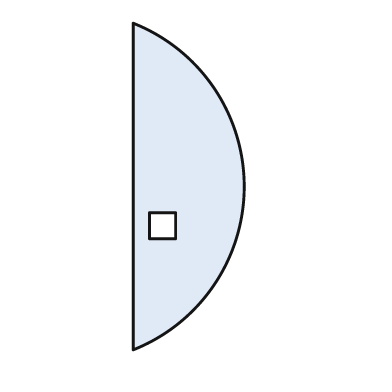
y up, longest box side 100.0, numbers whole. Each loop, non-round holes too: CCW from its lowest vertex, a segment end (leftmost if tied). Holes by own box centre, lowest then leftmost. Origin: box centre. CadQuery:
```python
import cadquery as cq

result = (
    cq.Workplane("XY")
    .moveTo(-17.0, -50.0)
    .threePointArc((17.0, 0.0), (-17.0, 50.0))
    .close()
    .moveTo(-12.0, -16.0)
    .lineTo(-4.0, -16.0)
    .lineTo(-4.0, -8.0)
    .lineTo(-12.0, -8.0)
    .close()
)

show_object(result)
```